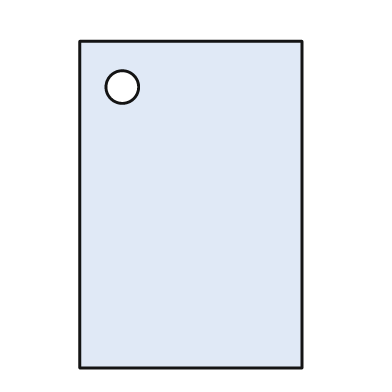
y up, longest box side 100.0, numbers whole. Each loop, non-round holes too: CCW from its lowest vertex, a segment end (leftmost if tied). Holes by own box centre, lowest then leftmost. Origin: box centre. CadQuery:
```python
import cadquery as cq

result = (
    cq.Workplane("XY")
    .moveTo(-34.0, -50.0)
    .lineTo(34.0, -50.0)
    .lineTo(34.0, 50.0)
    .lineTo(-34.0, 50.0)
    .close()
    .moveTo(-21.0, 36.0)
    .circle(5.0)
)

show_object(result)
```